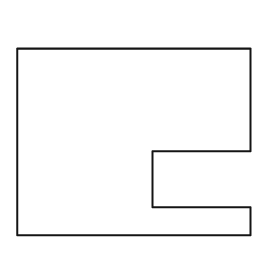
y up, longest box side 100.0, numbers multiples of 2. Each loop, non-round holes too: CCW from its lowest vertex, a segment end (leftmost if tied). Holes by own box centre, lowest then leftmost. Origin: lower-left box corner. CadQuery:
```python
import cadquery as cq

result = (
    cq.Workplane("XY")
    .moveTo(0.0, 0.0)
    .lineTo(100.0, 0.0)
    .lineTo(100.0, 12.0)
    .lineTo(58.0, 12.0)
    .lineTo(58.0, 36.0)
    .lineTo(100.0, 36.0)
    .lineTo(100.0, 80.0)
    .lineTo(0.0, 80.0)
    .close()
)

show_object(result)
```